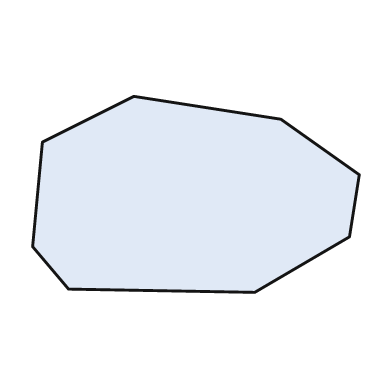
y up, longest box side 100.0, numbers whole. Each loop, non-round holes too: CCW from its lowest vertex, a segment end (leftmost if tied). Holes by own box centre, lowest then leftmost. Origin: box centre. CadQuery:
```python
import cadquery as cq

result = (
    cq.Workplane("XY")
    .moveTo(18.0, -30.0)
    .lineTo(47.0, -13.0)
    .lineTo(50.0, 6.0)
    .lineTo(26.0, 23.0)
    .lineTo(-19.0, 30.0)
    .lineTo(-47.0, 16.0)
    .lineTo(-50.0, -16.0)
    .lineTo(-39.0, -29.0)
    .close()
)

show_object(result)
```